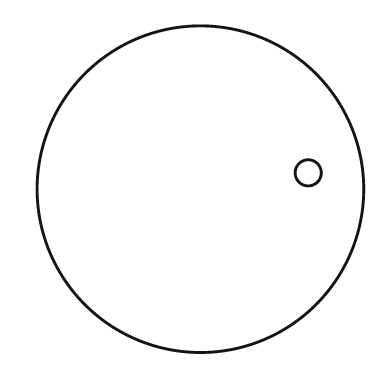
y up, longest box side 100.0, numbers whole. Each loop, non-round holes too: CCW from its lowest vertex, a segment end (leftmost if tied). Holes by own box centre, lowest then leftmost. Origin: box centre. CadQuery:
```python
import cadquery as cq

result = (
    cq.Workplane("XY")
    .moveTo(0.0, 0.0)
    .circle(50.0)
    .moveTo(33.0, 5.0)
    .circle(4.0)
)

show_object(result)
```